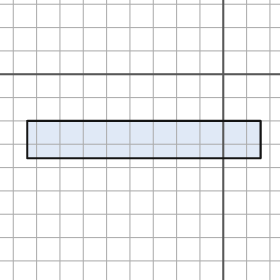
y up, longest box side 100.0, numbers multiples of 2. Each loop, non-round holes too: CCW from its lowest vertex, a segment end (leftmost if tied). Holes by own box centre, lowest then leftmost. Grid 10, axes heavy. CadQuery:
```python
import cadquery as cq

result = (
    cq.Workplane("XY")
    .moveTo(-84.0, -36.0)
    .lineTo(16.0, -36.0)
    .lineTo(16.0, -20.0)
    .lineTo(-84.0, -20.0)
    .close()
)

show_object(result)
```